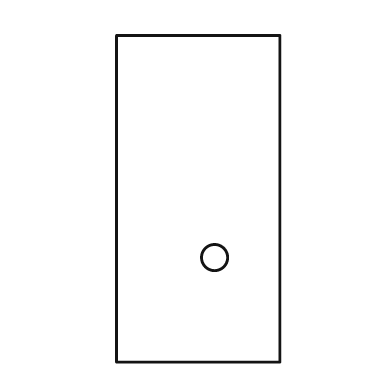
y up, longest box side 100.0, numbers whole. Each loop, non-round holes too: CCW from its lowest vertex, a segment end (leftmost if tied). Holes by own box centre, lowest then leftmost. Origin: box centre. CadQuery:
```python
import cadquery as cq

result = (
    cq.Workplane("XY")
    .moveTo(-25.0, -50.0)
    .lineTo(25.0, -50.0)
    .lineTo(25.0, 50.0)
    .lineTo(-25.0, 50.0)
    .close()
    .moveTo(5.0, -18.0)
    .circle(4.0)
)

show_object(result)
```